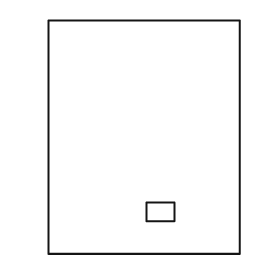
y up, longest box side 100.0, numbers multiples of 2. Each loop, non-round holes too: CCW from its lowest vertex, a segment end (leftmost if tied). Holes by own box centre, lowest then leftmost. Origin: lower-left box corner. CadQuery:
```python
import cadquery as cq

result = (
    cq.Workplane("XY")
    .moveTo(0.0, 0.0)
    .lineTo(82.0, 0.0)
    .lineTo(82.0, 100.0)
    .lineTo(0.0, 100.0)
    .close()
    .moveTo(42.0, 14.0)
    .lineTo(54.0, 14.0)
    .lineTo(54.0, 22.0)
    .lineTo(42.0, 22.0)
    .close()
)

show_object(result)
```